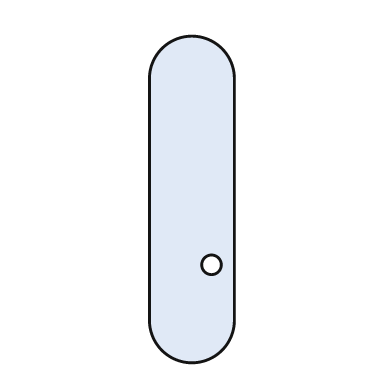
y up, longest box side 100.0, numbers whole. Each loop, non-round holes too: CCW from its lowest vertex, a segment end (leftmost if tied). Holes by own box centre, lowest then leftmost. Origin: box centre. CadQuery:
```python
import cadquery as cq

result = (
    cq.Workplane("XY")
    .moveTo(-13.0, -37.0)
    .threePointArc((0.0, -50.0), (13.0, -37.0))
    .lineTo(13.0, 37.0)
    .threePointArc((0.0, 50.0), (-13.0, 37.0))
    .close()
    .moveTo(6.0, -20.0)
    .circle(3.0)
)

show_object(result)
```